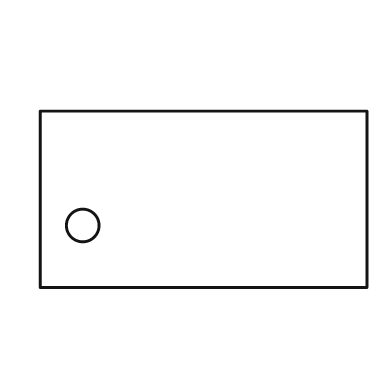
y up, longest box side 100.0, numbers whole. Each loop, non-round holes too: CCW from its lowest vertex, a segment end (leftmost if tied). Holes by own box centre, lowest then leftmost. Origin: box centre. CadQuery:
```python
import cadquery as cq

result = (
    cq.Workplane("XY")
    .moveTo(-50.0, -27.0)
    .lineTo(50.0, -27.0)
    .lineTo(50.0, 27.0)
    .lineTo(-50.0, 27.0)
    .close()
    .moveTo(-37.0, -8.0)
    .circle(5.0)
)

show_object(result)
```